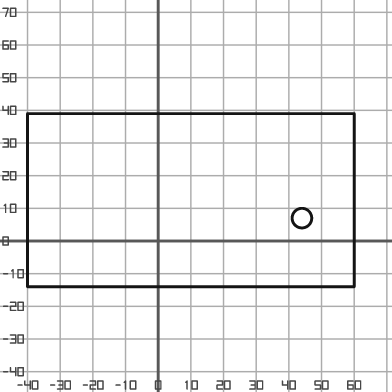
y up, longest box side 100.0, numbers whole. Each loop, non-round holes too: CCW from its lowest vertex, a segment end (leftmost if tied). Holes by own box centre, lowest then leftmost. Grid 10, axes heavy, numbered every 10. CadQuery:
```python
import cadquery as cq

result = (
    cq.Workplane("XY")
    .moveTo(-40.0, -14.0)
    .lineTo(60.0, -14.0)
    .lineTo(60.0, 39.0)
    .lineTo(-40.0, 39.0)
    .close()
    .moveTo(44.0, 7.0)
    .circle(3.0)
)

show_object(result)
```